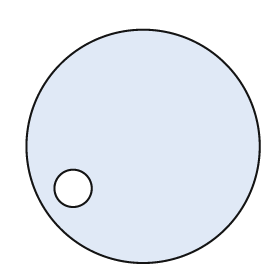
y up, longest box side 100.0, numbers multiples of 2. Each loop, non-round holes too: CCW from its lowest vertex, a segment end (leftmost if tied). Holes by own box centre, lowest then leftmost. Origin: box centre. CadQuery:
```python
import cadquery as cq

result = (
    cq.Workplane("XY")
    .moveTo(0.0, 0.0)
    .circle(50.0)
    .moveTo(-30.0, -18.0)
    .circle(8.0)
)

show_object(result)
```